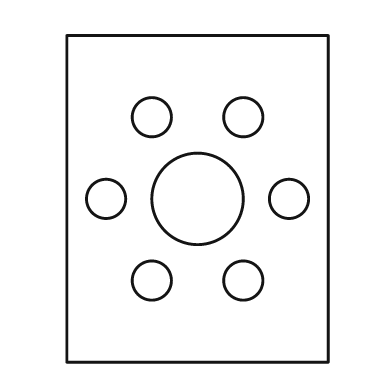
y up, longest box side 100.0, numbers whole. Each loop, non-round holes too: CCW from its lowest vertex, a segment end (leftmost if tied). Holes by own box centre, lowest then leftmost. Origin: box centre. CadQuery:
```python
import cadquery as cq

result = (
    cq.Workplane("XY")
    .moveTo(-40.0, -50.0)
    .lineTo(40.0, -50.0)
    .lineTo(40.0, 50.0)
    .lineTo(-40.0, 50.0)
    .close()
    .moveTo(-14.0, -25.0)
    .circle(6.0)
    .moveTo(14.0, -25.0)
    .circle(6.0)
    .moveTo(-28.0, 0.0)
    .circle(6.0)
    .moveTo(0.0, 0.0)
    .circle(14.0)
    .moveTo(28.0, 0.0)
    .circle(6.0)
    .moveTo(-14.0, 25.0)
    .circle(6.0)
    .moveTo(14.0, 25.0)
    .circle(6.0)
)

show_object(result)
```